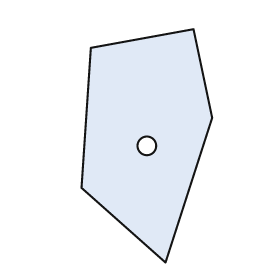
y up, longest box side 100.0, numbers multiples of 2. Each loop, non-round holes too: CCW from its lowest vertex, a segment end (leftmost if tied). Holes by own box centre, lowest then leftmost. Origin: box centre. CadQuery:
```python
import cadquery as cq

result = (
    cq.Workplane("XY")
    .moveTo(8.0, -50.0)
    .lineTo(28.0, 12.0)
    .lineTo(20.0, 50.0)
    .lineTo(-24.0, 42.0)
    .lineTo(-28.0, -18.0)
    .close()
    .moveTo(0.0, 0.0)
    .circle(4.0)
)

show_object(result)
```